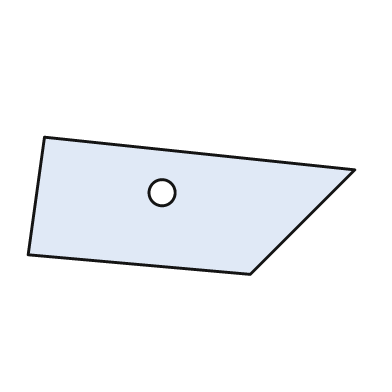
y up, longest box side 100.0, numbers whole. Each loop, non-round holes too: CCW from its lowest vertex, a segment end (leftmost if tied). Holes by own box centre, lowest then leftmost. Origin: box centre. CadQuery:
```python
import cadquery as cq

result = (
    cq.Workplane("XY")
    .moveTo(18.0, -21.0)
    .lineTo(50.0, 11.0)
    .lineTo(-45.0, 21.0)
    .lineTo(-50.0, -15.0)
    .close()
    .moveTo(-9.0, 4.0)
    .circle(4.0)
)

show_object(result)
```